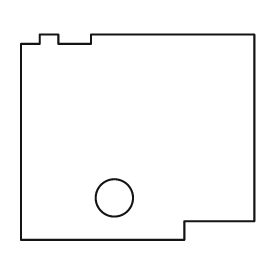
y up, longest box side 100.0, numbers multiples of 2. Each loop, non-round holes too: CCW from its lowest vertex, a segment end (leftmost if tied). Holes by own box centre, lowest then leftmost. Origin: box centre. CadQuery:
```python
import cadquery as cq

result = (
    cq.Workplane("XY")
    .moveTo(-50.0, -44.0)
    .lineTo(20.0, -44.0)
    .lineTo(20.0, -36.0)
    .lineTo(50.0, -36.0)
    .lineTo(50.0, 44.0)
    .lineTo(-20.0, 44.0)
    .lineTo(-20.0, 40.0)
    .lineTo(-34.0, 40.0)
    .lineTo(-34.0, 44.0)
    .lineTo(-42.0, 44.0)
    .lineTo(-42.0, 40.0)
    .lineTo(-50.0, 40.0)
    .close()
    .moveTo(-10.0, -26.0)
    .circle(8.0)
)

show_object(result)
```